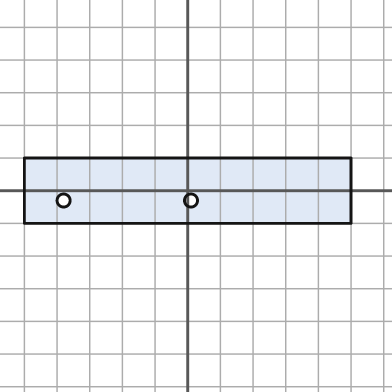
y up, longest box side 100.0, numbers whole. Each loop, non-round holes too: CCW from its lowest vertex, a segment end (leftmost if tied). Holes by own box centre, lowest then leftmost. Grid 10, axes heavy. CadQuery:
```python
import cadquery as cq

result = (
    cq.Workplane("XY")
    .moveTo(-50.0, -10.0)
    .lineTo(50.0, -10.0)
    .lineTo(50.0, 10.0)
    .lineTo(-50.0, 10.0)
    .close()
    .moveTo(-38.0, -3.0)
    .circle(2.0)
    .moveTo(1.0, -3.0)
    .circle(2.0)
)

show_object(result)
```